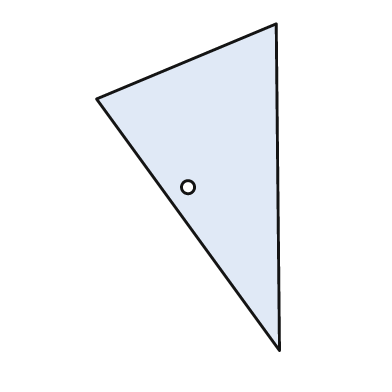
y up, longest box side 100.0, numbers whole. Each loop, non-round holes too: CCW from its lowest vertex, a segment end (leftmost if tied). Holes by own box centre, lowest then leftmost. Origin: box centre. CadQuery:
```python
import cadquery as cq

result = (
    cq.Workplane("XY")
    .moveTo(28.0, -50.0)
    .lineTo(27.0, 50.0)
    .lineTo(-28.0, 27.0)
    .close()
    .moveTo(0.0, 0.0)
    .circle(2.0)
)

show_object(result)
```